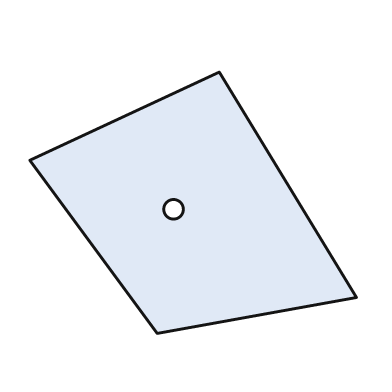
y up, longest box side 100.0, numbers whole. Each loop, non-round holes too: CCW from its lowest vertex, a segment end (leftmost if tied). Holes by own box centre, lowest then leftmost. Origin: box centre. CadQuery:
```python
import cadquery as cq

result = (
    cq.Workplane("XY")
    .moveTo(-11.0, -40.0)
    .lineTo(50.0, -29.0)
    .lineTo(8.0, 40.0)
    .lineTo(-50.0, 13.0)
    .close()
    .moveTo(-6.0, -2.0)
    .circle(3.0)
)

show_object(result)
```